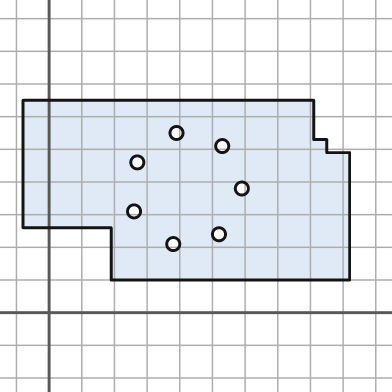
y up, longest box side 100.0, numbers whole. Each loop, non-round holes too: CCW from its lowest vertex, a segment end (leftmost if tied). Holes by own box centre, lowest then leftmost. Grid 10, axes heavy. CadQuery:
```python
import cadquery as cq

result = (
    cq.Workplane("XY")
    .moveTo(19.0, 10.0)
    .lineTo(92.0, 10.0)
    .lineTo(92.0, 49.0)
    .lineTo(85.0, 49.0)
    .lineTo(85.0, 53.0)
    .lineTo(81.0, 53.0)
    .lineTo(81.0, 65.0)
    .lineTo(-8.0, 65.0)
    .lineTo(-8.0, 26.0)
    .lineTo(19.0, 26.0)
    .close()
    .moveTo(38.0, 21.0)
    .circle(2.0)
    .moveTo(52.0, 24.0)
    .circle(2.0)
    .moveTo(26.0, 31.0)
    .circle(2.0)
    .moveTo(59.0, 38.0)
    .circle(2.0)
    .moveTo(27.0, 46.0)
    .circle(2.0)
    .moveTo(53.0, 51.0)
    .circle(2.0)
    .moveTo(39.0, 55.0)
    .circle(2.0)
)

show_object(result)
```